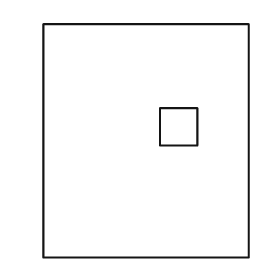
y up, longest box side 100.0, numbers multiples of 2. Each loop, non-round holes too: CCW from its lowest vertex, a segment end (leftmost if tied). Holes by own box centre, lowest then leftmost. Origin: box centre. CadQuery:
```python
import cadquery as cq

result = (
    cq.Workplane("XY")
    .moveTo(-44.0, -50.0)
    .lineTo(44.0, -50.0)
    .lineTo(44.0, 50.0)
    .lineTo(-44.0, 50.0)
    .close()
    .moveTo(6.0, -2.0)
    .lineTo(22.0, -2.0)
    .lineTo(22.0, 14.0)
    .lineTo(6.0, 14.0)
    .close()
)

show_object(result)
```